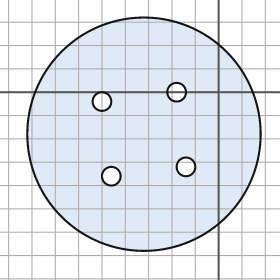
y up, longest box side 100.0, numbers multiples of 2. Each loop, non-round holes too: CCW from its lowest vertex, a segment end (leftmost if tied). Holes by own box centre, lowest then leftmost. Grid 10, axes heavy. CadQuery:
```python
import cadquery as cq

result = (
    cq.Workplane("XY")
    .moveTo(-32.0, -18.0)
    .circle(50.0)
    .moveTo(-46.0, -36.0)
    .circle(4.0)
    .moveTo(-14.0, -32.0)
    .circle(4.0)
    .moveTo(-50.0, -4.0)
    .circle(4.0)
    .moveTo(-18.0, 0.0)
    .circle(4.0)
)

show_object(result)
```